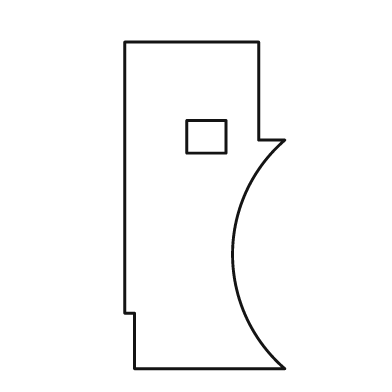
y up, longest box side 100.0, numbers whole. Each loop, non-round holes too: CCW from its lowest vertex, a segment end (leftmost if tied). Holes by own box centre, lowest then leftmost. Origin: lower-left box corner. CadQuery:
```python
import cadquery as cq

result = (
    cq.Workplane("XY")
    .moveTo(3.0, 0.0)
    .lineTo(49.0, 0.0)
    .threePointArc((33.0, 35.0), (49.0, 70.0))
    .lineTo(41.0, 70.0)
    .lineTo(41.0, 100.0)
    .lineTo(0.0, 100.0)
    .lineTo(0.0, 17.0)
    .lineTo(3.0, 17.0)
    .close()
    .moveTo(19.0, 66.0)
    .lineTo(31.0, 66.0)
    .lineTo(31.0, 76.0)
    .lineTo(19.0, 76.0)
    .close()
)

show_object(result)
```